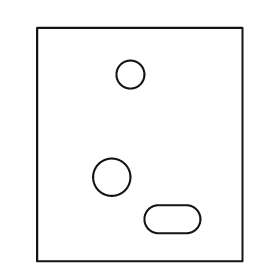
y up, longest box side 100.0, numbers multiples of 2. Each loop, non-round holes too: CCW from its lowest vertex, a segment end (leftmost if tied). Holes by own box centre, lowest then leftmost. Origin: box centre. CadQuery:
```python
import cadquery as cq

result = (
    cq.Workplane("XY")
    .moveTo(-44.0, -50.0)
    .lineTo(44.0, -50.0)
    .lineTo(44.0, 50.0)
    .lineTo(-44.0, 50.0)
    .close()
    .moveTo(8.0, -38.0)
    .lineTo(20.0, -38.0)
    .threePointArc((26.0, -32.0), (20.0, -26.0))
    .lineTo(8.0, -26.0)
    .threePointArc((2.0, -32.0), (8.0, -38.0))
    .close()
    .moveTo(-12.0, -14.0)
    .circle(8.0)
    .moveTo(-4.0, 30.0)
    .circle(6.0)
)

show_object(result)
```